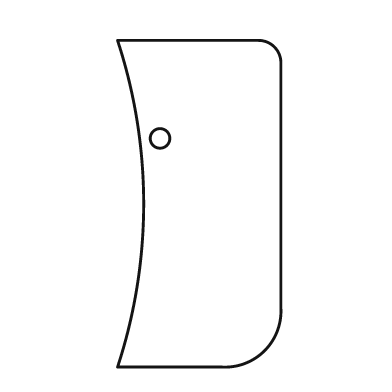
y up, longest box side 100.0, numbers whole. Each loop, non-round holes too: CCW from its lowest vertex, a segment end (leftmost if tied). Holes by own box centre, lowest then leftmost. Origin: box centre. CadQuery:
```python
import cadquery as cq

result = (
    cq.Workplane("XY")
    .moveTo(-25.0, -50.0)
    .lineTo(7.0, -50.0)
    .threePointArc((20.0, -45.0), (25.0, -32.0))
    .lineTo(25.0, 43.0)
    .threePointArc((23.0, 48.0), (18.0, 50.0))
    .lineTo(-25.0, 50.0)
    .threePointArc((-17.0, 0.0), (-25.0, -50.0))
    .close()
    .moveTo(-12.0, 20.0)
    .circle(3.0)
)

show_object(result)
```